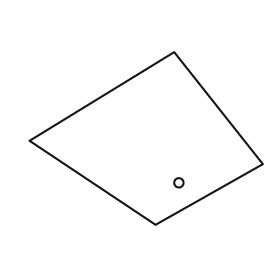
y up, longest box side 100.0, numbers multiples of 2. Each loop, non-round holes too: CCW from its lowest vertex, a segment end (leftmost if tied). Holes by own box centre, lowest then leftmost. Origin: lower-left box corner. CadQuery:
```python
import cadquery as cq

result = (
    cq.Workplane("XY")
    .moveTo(54.0, 0.0)
    .lineTo(100.0, 26.0)
    .lineTo(62.0, 74.0)
    .lineTo(0.0, 36.0)
    .close()
    .moveTo(64.0, 18.0)
    .circle(2.0)
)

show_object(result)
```